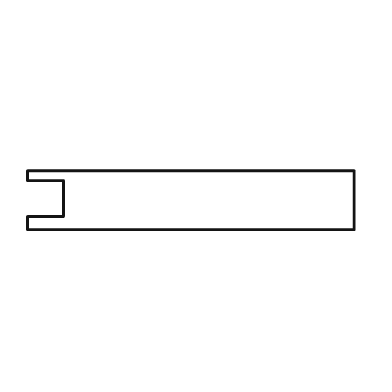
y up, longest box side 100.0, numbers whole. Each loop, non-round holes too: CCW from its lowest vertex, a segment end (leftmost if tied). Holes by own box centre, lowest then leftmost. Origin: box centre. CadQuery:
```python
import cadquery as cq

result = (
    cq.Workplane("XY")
    .moveTo(-50.0, -9.0)
    .lineTo(50.0, -9.0)
    .lineTo(50.0, 9.0)
    .lineTo(-50.0, 9.0)
    .lineTo(-50.0, 6.0)
    .lineTo(-39.0, 6.0)
    .lineTo(-39.0, -5.0)
    .lineTo(-50.0, -5.0)
    .close()
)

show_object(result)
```